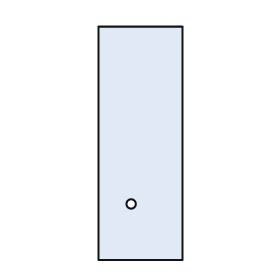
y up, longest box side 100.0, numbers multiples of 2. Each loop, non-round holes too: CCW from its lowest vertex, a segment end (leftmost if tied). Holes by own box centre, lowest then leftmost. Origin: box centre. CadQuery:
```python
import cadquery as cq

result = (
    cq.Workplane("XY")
    .moveTo(-18.0, -50.0)
    .lineTo(18.0, -50.0)
    .lineTo(18.0, 50.0)
    .lineTo(-18.0, 50.0)
    .close()
    .moveTo(-4.0, -26.0)
    .circle(2.0)
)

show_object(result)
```